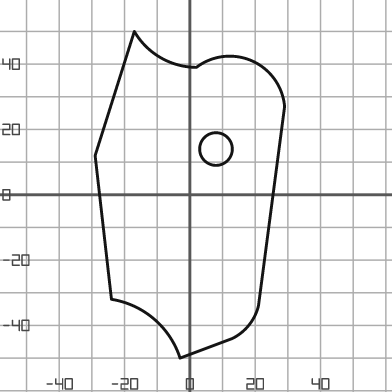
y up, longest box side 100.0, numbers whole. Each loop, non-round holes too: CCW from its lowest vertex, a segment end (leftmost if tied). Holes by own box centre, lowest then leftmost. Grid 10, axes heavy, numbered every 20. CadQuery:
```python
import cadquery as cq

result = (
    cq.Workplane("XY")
    .moveTo(-3.0, -50.0)
    .lineTo(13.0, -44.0)
    .threePointArc((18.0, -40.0), (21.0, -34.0))
    .lineTo(29.0, 27.0)
    .threePointArc((19.0, 41.0), (2.0, 39.0))
    .threePointArc((-9.0, 42.0), (-17.0, 50.0))
    .lineTo(-29.0, 12.0)
    .lineTo(-24.0, -32.0)
    .threePointArc((-11.0, -38.0), (-3.0, -50.0))
    .close()
    .moveTo(8.0, 14.0)
    .circle(5.0)
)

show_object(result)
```